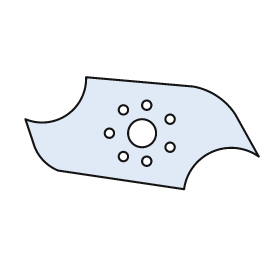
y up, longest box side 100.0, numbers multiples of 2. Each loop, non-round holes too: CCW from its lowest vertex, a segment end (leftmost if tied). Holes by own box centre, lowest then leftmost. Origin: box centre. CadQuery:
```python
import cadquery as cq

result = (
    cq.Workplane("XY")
    .moveTo(18.0, -24.0)
    .threePointArc((30.0, -8.0), (50.0, -10.0))
    .lineTo(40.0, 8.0)
    .threePointArc((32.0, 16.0), (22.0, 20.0))
    .lineTo(-24.0, 24.0)
    .threePointArc((-32.0, 8.0), (-50.0, 6.0))
    .lineTo(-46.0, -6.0)
    .threePointArc((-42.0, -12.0), (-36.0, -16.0))
    .close()
    .moveTo(2.0, -12.0)
    .circle(2.0)
    .moveTo(-8.0, -10.0)
    .circle(2.0)
    .moveTo(12.0, -6.0)
    .circle(2.0)
    .moveTo(-14.0, 0.0)
    .circle(2.0)
    .moveTo(0.0, 0.0)
    .circle(6.0)
    .moveTo(12.0, 6.0)
    .circle(2.0)
    .moveTo(-8.0, 10.0)
    .circle(2.0)
    .moveTo(2.0, 12.0)
    .circle(2.0)
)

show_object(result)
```